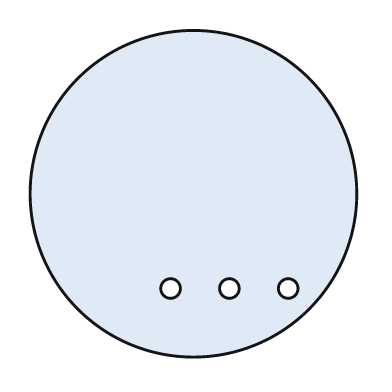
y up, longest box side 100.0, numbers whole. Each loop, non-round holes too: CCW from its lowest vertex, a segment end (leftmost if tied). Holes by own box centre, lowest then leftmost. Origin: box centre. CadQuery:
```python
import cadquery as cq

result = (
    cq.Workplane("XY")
    .moveTo(0.0, 0.0)
    .circle(50.0)
    .moveTo(-7.0, -29.0)
    .circle(3.0)
    .moveTo(11.0, -29.0)
    .circle(3.0)
    .moveTo(29.0, -29.0)
    .circle(3.0)
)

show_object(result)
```